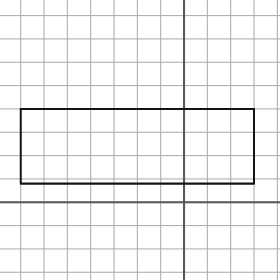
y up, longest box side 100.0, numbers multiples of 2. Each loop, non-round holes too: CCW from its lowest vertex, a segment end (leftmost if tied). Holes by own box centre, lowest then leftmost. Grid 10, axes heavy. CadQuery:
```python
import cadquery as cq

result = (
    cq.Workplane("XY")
    .moveTo(-70.0, 8.0)
    .lineTo(30.0, 8.0)
    .lineTo(30.0, 40.0)
    .lineTo(-70.0, 40.0)
    .close()
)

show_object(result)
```